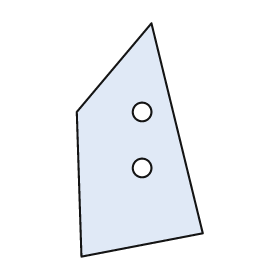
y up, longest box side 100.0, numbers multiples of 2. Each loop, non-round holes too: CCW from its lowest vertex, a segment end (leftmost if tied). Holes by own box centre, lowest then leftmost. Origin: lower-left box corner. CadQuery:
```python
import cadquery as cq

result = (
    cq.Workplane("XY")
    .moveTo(2.0, 0.0)
    .lineTo(54.0, 10.0)
    .lineTo(32.0, 100.0)
    .lineTo(0.0, 62.0)
    .close()
    .moveTo(28.0, 38.0)
    .circle(4.0)
    .moveTo(28.0, 62.0)
    .circle(4.0)
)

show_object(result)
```